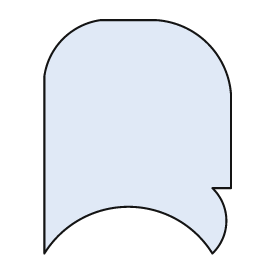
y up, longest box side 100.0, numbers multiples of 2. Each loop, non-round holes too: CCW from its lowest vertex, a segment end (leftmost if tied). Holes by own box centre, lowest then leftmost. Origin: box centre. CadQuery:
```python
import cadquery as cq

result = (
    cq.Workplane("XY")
    .moveTo(-40.0, -50.0)
    .threePointArc((-4.0, -30.0), (32.0, -50.0))
    .threePointArc((38.0, -36.0), (32.0, -22.0))
    .lineTo(40.0, -22.0)
    .lineTo(40.0, 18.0)
    .threePointArc((30.0, 40.0), (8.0, 50.0))
    .lineTo(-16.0, 50.0)
    .threePointArc((-32.0, 42.0), (-40.0, 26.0))
    .close()
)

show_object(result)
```